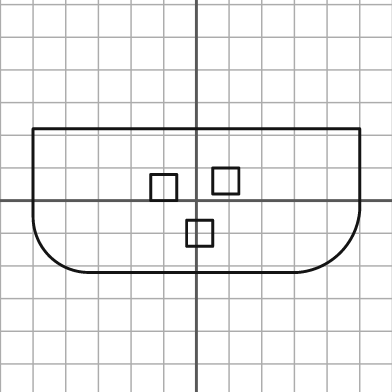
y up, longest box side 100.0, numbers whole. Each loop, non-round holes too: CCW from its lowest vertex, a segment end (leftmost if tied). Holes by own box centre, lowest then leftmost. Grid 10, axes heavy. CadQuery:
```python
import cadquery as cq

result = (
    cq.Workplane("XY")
    .moveTo(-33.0, -22.0)
    .lineTo(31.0, -22.0)
    .threePointArc((44.0, -16.0), (50.0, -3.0))
    .lineTo(50.0, 22.0)
    .lineTo(-50.0, 22.0)
    .lineTo(-50.0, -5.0)
    .threePointArc((-45.0, -17.0), (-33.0, -22.0))
    .close()
    .moveTo(-3.0, -14.0)
    .lineTo(5.0, -14.0)
    .lineTo(5.0, -6.0)
    .lineTo(-3.0, -6.0)
    .close()
    .moveTo(-14.0, 0.0)
    .lineTo(-6.0, 0.0)
    .lineTo(-6.0, 8.0)
    .lineTo(-14.0, 8.0)
    .close()
    .moveTo(5.0, 2.0)
    .lineTo(13.0, 2.0)
    .lineTo(13.0, 10.0)
    .lineTo(5.0, 10.0)
    .close()
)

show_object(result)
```